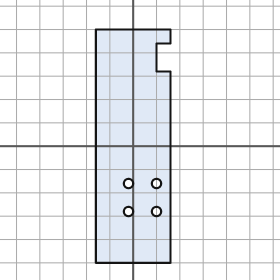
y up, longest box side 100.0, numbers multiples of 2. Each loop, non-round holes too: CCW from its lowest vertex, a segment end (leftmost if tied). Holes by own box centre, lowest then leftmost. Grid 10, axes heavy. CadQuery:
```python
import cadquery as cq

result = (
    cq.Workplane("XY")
    .moveTo(-16.0, -50.0)
    .lineTo(16.0, -50.0)
    .lineTo(16.0, 32.0)
    .lineTo(10.0, 32.0)
    .lineTo(10.0, 44.0)
    .lineTo(16.0, 44.0)
    .lineTo(16.0, 50.0)
    .lineTo(-16.0, 50.0)
    .close()
    .moveTo(-2.0, -28.0)
    .circle(2.0)
    .moveTo(10.0, -28.0)
    .circle(2.0)
    .moveTo(-2.0, -16.0)
    .circle(2.0)
    .moveTo(10.0, -16.0)
    .circle(2.0)
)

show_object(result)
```